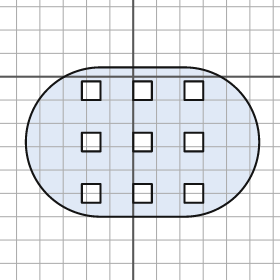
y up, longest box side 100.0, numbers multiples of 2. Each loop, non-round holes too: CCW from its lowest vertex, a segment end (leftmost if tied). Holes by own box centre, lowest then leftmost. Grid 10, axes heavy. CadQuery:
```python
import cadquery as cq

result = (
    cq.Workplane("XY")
    .moveTo(-14.0, -60.0)
    .lineTo(22.0, -60.0)
    .threePointArc((54.0, -28.0), (22.0, 4.0))
    .lineTo(-14.0, 4.0)
    .threePointArc((-46.0, -28.0), (-14.0, -60.0))
    .close()
    .moveTo(-22.0, -54.0)
    .lineTo(-14.0, -54.0)
    .lineTo(-14.0, -46.0)
    .lineTo(-22.0, -46.0)
    .close()
    .moveTo(0.0, -54.0)
    .lineTo(8.0, -54.0)
    .lineTo(8.0, -46.0)
    .lineTo(0.0, -46.0)
    .close()
    .moveTo(22.0, -54.0)
    .lineTo(30.0, -54.0)
    .lineTo(30.0, -46.0)
    .lineTo(22.0, -46.0)
    .close()
    .moveTo(-22.0, -32.0)
    .lineTo(-14.0, -32.0)
    .lineTo(-14.0, -24.0)
    .lineTo(-22.0, -24.0)
    .close()
    .moveTo(0.0, -32.0)
    .lineTo(8.0, -32.0)
    .lineTo(8.0, -24.0)
    .lineTo(0.0, -24.0)
    .close()
    .moveTo(22.0, -32.0)
    .lineTo(30.0, -32.0)
    .lineTo(30.0, -24.0)
    .lineTo(22.0, -24.0)
    .close()
    .moveTo(-22.0, -10.0)
    .lineTo(-14.0, -10.0)
    .lineTo(-14.0, -2.0)
    .lineTo(-22.0, -2.0)
    .close()
    .moveTo(0.0, -10.0)
    .lineTo(8.0, -10.0)
    .lineTo(8.0, -2.0)
    .lineTo(0.0, -2.0)
    .close()
    .moveTo(22.0, -10.0)
    .lineTo(30.0, -10.0)
    .lineTo(30.0, -2.0)
    .lineTo(22.0, -2.0)
    .close()
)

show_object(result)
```